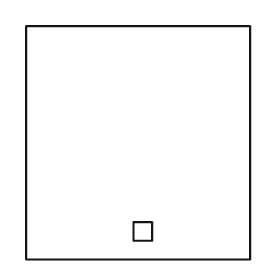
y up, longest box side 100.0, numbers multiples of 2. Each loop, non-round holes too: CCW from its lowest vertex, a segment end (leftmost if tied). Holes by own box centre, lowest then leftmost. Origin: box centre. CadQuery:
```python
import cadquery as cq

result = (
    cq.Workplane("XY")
    .moveTo(-48.0, -50.0)
    .lineTo(48.0, -50.0)
    .lineTo(48.0, 50.0)
    .lineTo(-48.0, 50.0)
    .close()
    .moveTo(-2.0, -42.0)
    .lineTo(6.0, -42.0)
    .lineTo(6.0, -34.0)
    .lineTo(-2.0, -34.0)
    .close()
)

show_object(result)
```